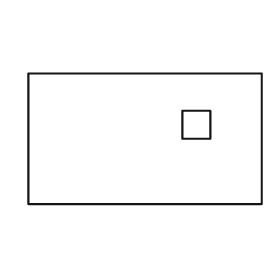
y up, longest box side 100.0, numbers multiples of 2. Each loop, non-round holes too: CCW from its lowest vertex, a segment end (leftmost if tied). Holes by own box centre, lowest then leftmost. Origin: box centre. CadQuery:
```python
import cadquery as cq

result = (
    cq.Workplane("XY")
    .moveTo(-50.0, -28.0)
    .lineTo(50.0, -28.0)
    .lineTo(50.0, 28.0)
    .lineTo(-50.0, 28.0)
    .close()
    .moveTo(16.0, 0.0)
    .lineTo(28.0, 0.0)
    .lineTo(28.0, 12.0)
    .lineTo(16.0, 12.0)
    .close()
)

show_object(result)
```